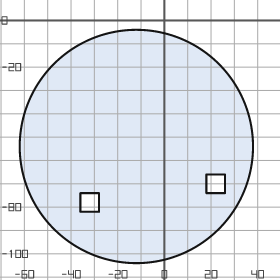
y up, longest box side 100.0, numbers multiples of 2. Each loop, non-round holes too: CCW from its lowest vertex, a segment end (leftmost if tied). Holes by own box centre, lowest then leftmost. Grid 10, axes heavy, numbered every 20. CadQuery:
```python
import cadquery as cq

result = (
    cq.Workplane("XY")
    .moveTo(-12.0, -54.0)
    .circle(50.0)
    .moveTo(-36.0, -82.0)
    .lineTo(-28.0, -82.0)
    .lineTo(-28.0, -74.0)
    .lineTo(-36.0, -74.0)
    .close()
    .moveTo(18.0, -74.0)
    .lineTo(26.0, -74.0)
    .lineTo(26.0, -66.0)
    .lineTo(18.0, -66.0)
    .close()
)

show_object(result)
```